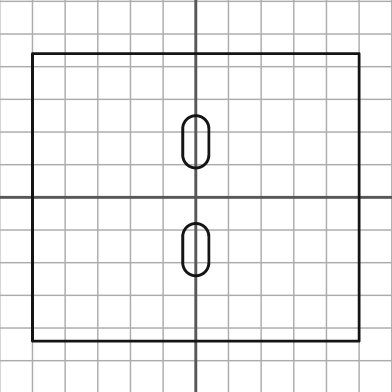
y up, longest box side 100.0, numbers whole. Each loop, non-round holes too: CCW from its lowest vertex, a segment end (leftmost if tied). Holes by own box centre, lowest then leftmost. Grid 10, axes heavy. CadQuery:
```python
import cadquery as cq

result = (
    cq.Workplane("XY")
    .moveTo(-50.0, -44.0)
    .lineTo(50.0, -44.0)
    .lineTo(50.0, 44.0)
    .lineTo(-50.0, 44.0)
    .close()
    .moveTo(-4.0, -20.0)
    .threePointArc((0.0, -24.0), (4.0, -20.0))
    .lineTo(4.0, -12.0)
    .threePointArc((0.0, -8.0), (-4.0, -12.0))
    .close()
    .moveTo(-4.0, 13.0)
    .threePointArc((0.0, 9.0), (4.0, 13.0))
    .lineTo(4.0, 21.0)
    .threePointArc((0.0, 25.0), (-4.0, 21.0))
    .close()
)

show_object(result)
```